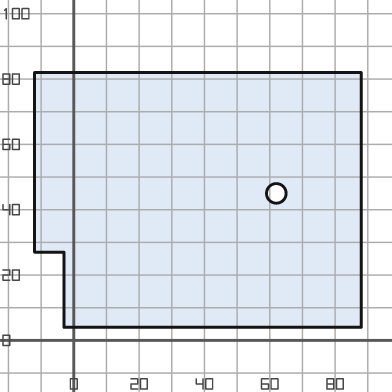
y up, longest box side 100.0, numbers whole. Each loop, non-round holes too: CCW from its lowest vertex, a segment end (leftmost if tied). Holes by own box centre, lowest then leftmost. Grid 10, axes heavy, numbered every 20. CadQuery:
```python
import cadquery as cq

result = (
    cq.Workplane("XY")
    .moveTo(-3.0, 4.0)
    .lineTo(88.0, 4.0)
    .lineTo(88.0, 82.0)
    .lineTo(-12.0, 82.0)
    .lineTo(-12.0, 27.0)
    .lineTo(-3.0, 27.0)
    .close()
    .moveTo(62.0, 45.0)
    .circle(3.0)
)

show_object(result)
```